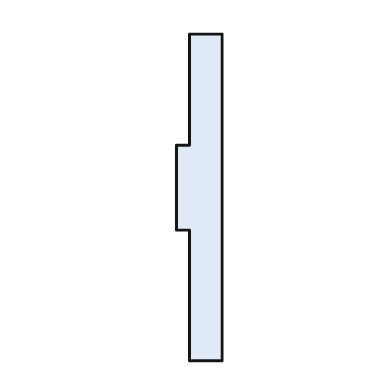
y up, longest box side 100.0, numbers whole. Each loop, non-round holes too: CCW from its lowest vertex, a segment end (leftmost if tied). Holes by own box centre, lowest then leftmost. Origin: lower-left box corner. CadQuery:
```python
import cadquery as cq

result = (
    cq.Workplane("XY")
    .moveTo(4.0, 0.0)
    .lineTo(14.0, 0.0)
    .lineTo(14.0, 100.0)
    .lineTo(4.0, 100.0)
    .lineTo(4.0, 66.0)
    .lineTo(0.0, 66.0)
    .lineTo(0.0, 40.0)
    .lineTo(4.0, 40.0)
    .close()
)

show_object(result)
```